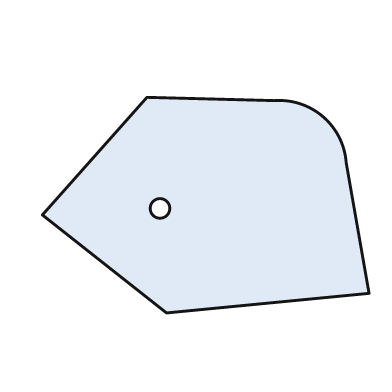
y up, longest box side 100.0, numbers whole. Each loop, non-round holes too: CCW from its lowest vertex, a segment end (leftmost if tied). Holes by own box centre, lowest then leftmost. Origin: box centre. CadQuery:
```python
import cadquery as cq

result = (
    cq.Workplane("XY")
    .moveTo(-12.0, -33.0)
    .lineTo(50.0, -27.0)
    .lineTo(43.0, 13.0)
    .threePointArc((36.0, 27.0), (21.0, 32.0))
    .lineTo(-18.0, 33.0)
    .lineTo(-50.0, -3.0)
    .close()
    .moveTo(-14.0, -1.0)
    .circle(3.0)
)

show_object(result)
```